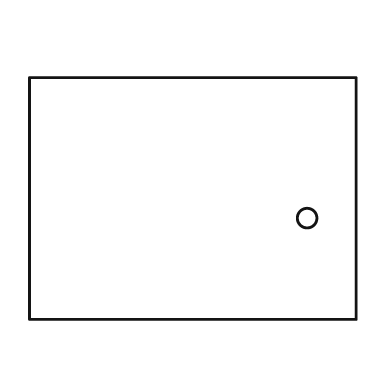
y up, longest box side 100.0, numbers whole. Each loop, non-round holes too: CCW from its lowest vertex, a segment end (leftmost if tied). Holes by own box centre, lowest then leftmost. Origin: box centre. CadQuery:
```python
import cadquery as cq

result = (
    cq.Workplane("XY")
    .moveTo(-50.0, -37.0)
    .lineTo(50.0, -37.0)
    .lineTo(50.0, 37.0)
    .lineTo(-50.0, 37.0)
    .close()
    .moveTo(35.0, -6.0)
    .circle(3.0)
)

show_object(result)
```